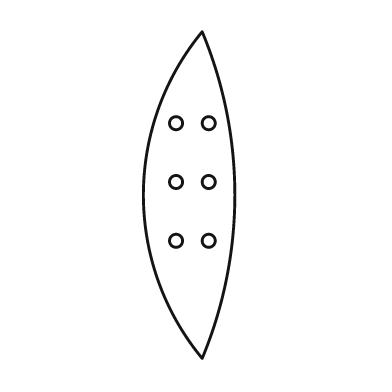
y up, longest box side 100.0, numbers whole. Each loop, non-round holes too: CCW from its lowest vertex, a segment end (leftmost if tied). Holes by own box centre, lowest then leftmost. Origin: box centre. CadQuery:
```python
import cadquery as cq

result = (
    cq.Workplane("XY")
    .moveTo(4.0, -50.0)
    .threePointArc((14.0, 0.0), (4.0, 50.0))
    .threePointArc((-14.0, 0.0), (4.0, -50.0))
    .close()
    .moveTo(-4.0, -14.0)
    .circle(2.0)
    .moveTo(6.0, -14.0)
    .circle(2.0)
    .moveTo(-4.0, 4.0)
    .circle(2.0)
    .moveTo(6.0, 4.0)
    .circle(2.0)
    .moveTo(-4.0, 22.0)
    .circle(2.0)
    .moveTo(6.0, 22.0)
    .circle(2.0)
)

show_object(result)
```